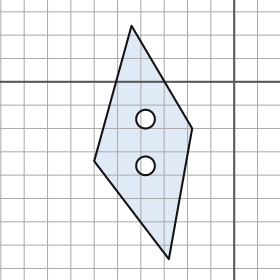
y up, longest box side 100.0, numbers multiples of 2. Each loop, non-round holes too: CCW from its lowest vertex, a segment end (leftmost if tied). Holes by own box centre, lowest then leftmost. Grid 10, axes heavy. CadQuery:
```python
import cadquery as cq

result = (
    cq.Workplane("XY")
    .moveTo(-28.0, -76.0)
    .lineTo(-18.0, -20.0)
    .lineTo(-44.0, 24.0)
    .lineTo(-60.0, -34.0)
    .close()
    .moveTo(-38.0, -36.0)
    .circle(4.0)
    .moveTo(-38.0, -16.0)
    .circle(4.0)
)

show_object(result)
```